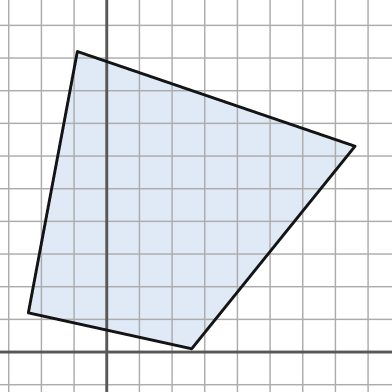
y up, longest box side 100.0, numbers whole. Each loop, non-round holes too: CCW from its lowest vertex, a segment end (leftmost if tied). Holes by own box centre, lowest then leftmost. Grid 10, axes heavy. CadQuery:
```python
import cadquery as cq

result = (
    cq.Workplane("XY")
    .moveTo(26.0, 1.0)
    .lineTo(76.0, 63.0)
    .lineTo(-9.0, 92.0)
    .lineTo(-24.0, 12.0)
    .close()
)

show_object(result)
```